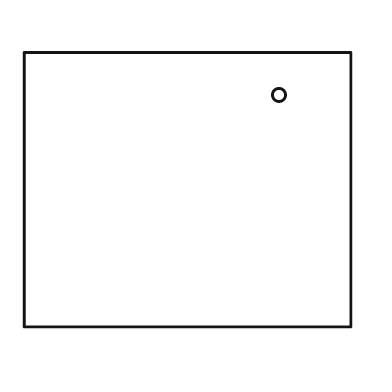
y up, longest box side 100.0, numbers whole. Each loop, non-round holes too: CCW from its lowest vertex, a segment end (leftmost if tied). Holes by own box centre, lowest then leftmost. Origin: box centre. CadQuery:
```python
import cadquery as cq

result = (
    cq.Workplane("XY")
    .moveTo(-50.0, -42.0)
    .lineTo(50.0, -42.0)
    .lineTo(50.0, 42.0)
    .lineTo(-50.0, 42.0)
    .close()
    .moveTo(28.0, 29.0)
    .circle(2.0)
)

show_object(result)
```